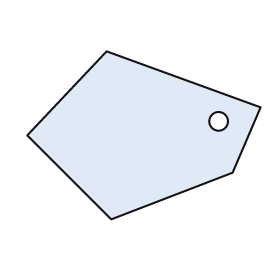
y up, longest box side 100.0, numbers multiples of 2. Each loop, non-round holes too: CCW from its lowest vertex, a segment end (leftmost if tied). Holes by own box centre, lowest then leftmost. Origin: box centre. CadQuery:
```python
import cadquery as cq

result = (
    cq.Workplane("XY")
    .moveTo(-14.0, -36.0)
    .lineTo(38.0, -16.0)
    .lineTo(50.0, 12.0)
    .lineTo(-16.0, 36.0)
    .lineTo(-50.0, 0.0)
    .close()
    .moveTo(32.0, 6.0)
    .circle(4.0)
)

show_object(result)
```